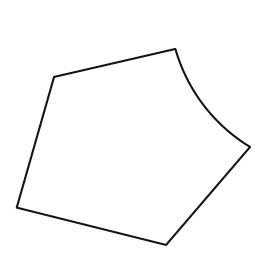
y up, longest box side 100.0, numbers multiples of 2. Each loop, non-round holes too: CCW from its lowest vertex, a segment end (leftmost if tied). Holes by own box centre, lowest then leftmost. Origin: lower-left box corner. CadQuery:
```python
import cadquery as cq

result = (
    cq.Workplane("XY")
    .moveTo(64.0, 0.0)
    .lineTo(100.0, 42.0)
    .threePointArc((80.0, 60.0), (68.0, 84.0))
    .lineTo(16.0, 72.0)
    .lineTo(0.0, 16.0)
    .close()
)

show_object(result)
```